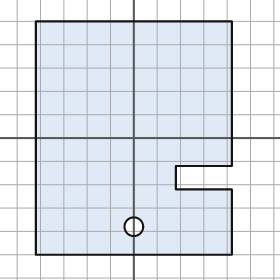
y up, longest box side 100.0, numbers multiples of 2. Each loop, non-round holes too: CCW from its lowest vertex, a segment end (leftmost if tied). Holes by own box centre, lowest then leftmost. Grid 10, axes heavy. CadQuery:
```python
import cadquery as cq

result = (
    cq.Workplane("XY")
    .moveTo(-42.0, -50.0)
    .lineTo(42.0, -50.0)
    .lineTo(42.0, -22.0)
    .lineTo(18.0, -22.0)
    .lineTo(18.0, -12.0)
    .lineTo(42.0, -12.0)
    .lineTo(42.0, 50.0)
    .lineTo(-42.0, 50.0)
    .close()
    .moveTo(0.0, -38.0)
    .circle(4.0)
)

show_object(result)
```